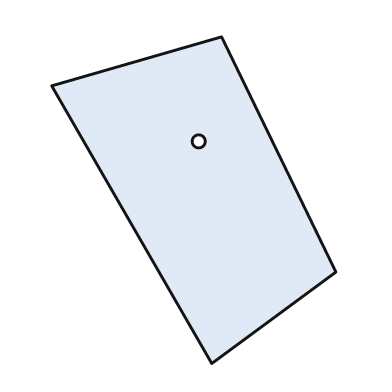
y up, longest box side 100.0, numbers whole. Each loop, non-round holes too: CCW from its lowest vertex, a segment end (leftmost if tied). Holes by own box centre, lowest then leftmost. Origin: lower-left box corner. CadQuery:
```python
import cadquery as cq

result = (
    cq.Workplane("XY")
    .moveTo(49.0, 0.0)
    .lineTo(87.0, 28.0)
    .lineTo(52.0, 100.0)
    .lineTo(0.0, 85.0)
    .close()
    .moveTo(45.0, 68.0)
    .circle(2.0)
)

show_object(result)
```